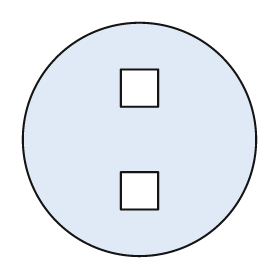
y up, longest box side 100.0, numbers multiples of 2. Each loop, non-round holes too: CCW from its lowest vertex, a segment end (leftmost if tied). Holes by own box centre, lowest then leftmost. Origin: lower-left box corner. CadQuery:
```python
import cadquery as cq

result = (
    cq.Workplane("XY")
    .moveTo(50.0, 50.0)
    .circle(50.0)
    .moveTo(42.0, 20.0)
    .lineTo(58.0, 20.0)
    .lineTo(58.0, 36.0)
    .lineTo(42.0, 36.0)
    .close()
    .moveTo(42.0, 64.0)
    .lineTo(58.0, 64.0)
    .lineTo(58.0, 80.0)
    .lineTo(42.0, 80.0)
    .close()
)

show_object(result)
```